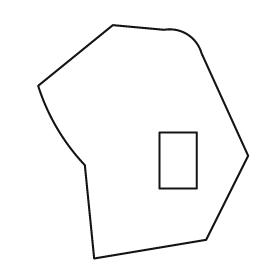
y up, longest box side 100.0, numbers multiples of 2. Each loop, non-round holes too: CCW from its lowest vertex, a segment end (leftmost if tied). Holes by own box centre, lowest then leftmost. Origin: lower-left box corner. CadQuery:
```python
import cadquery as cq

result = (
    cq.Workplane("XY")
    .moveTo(24.0, 0.0)
    .lineTo(72.0, 8.0)
    .lineTo(90.0, 44.0)
    .lineTo(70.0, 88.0)
    .threePointArc((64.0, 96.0), (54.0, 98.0))
    .lineTo(32.0, 100.0)
    .lineTo(0.0, 74.0)
    .threePointArc((8.0, 56.0), (20.0, 40.0))
    .close()
    .moveTo(52.0, 30.0)
    .lineTo(68.0, 30.0)
    .lineTo(68.0, 54.0)
    .lineTo(52.0, 54.0)
    .close()
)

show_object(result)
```